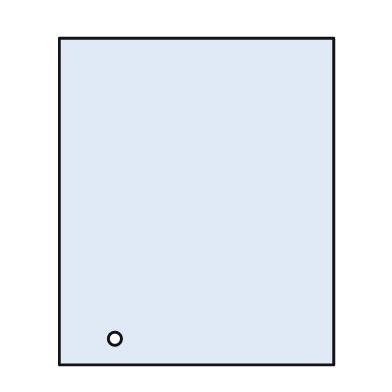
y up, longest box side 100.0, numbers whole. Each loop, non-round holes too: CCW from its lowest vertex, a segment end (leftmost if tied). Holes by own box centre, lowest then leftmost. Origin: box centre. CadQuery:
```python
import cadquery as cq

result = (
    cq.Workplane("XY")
    .moveTo(-42.0, -50.0)
    .lineTo(42.0, -50.0)
    .lineTo(42.0, 50.0)
    .lineTo(-42.0, 50.0)
    .close()
    .moveTo(-25.0, -42.0)
    .circle(2.0)
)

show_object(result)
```